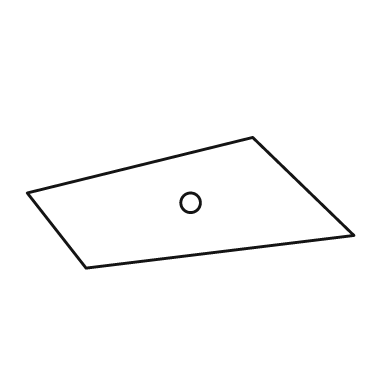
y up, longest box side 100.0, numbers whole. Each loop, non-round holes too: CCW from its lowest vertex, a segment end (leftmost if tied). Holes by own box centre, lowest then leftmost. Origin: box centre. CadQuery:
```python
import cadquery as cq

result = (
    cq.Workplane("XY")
    .moveTo(-32.0, -20.0)
    .lineTo(50.0, -10.0)
    .lineTo(19.0, 20.0)
    .lineTo(-50.0, 3.0)
    .close()
    .moveTo(0.0, 0.0)
    .circle(3.0)
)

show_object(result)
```